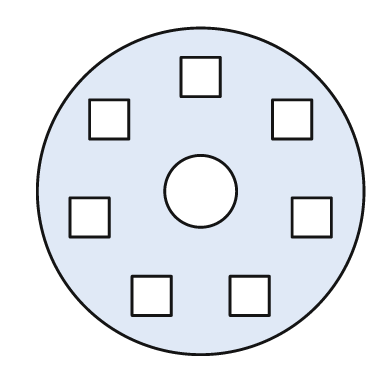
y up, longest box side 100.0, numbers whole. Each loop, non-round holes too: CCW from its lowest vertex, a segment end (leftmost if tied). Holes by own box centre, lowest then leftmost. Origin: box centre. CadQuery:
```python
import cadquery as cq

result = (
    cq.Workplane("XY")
    .moveTo(0.0, 0.0)
    .circle(50.0)
    .moveTo(-21.0, -38.0)
    .lineTo(-9.0, -38.0)
    .lineTo(-9.0, -26.0)
    .lineTo(-21.0, -26.0)
    .close()
    .moveTo(9.0, -38.0)
    .lineTo(21.0, -38.0)
    .lineTo(21.0, -26.0)
    .lineTo(9.0, -26.0)
    .close()
    .moveTo(-40.0, -14.0)
    .lineTo(-28.0, -14.0)
    .lineTo(-28.0, -2.0)
    .lineTo(-40.0, -2.0)
    .close()
    .moveTo(28.0, -14.0)
    .lineTo(40.0, -14.0)
    .lineTo(40.0, -2.0)
    .lineTo(28.0, -2.0)
    .close()
    .moveTo(0.0, 0.0)
    .circle(11.0)
    .moveTo(-34.0, 16.0)
    .lineTo(-22.0, 16.0)
    .lineTo(-22.0, 28.0)
    .lineTo(-34.0, 28.0)
    .close()
    .moveTo(22.0, 16.0)
    .lineTo(34.0, 16.0)
    .lineTo(34.0, 28.0)
    .lineTo(22.0, 28.0)
    .close()
    .moveTo(-6.0, 29.0)
    .lineTo(6.0, 29.0)
    .lineTo(6.0, 41.0)
    .lineTo(-6.0, 41.0)
    .close()
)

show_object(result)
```